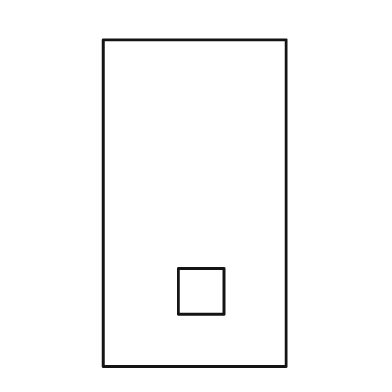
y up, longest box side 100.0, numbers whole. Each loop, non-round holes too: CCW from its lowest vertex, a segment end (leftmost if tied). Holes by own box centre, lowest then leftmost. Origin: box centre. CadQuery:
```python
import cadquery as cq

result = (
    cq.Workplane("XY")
    .moveTo(-28.0, -50.0)
    .lineTo(28.0, -50.0)
    .lineTo(28.0, 50.0)
    .lineTo(-28.0, 50.0)
    .close()
    .moveTo(-5.0, -34.0)
    .lineTo(9.0, -34.0)
    .lineTo(9.0, -20.0)
    .lineTo(-5.0, -20.0)
    .close()
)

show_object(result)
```